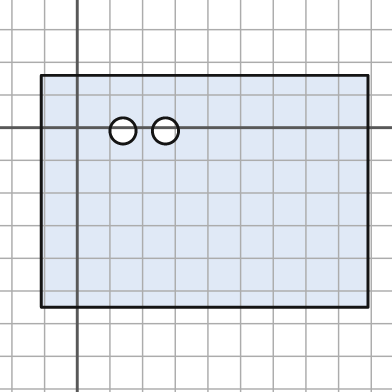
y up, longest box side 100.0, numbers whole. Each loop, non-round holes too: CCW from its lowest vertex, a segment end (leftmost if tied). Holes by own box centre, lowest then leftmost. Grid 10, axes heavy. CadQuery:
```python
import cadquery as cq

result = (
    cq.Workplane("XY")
    .moveTo(-11.0, -55.0)
    .lineTo(89.0, -55.0)
    .lineTo(89.0, 16.0)
    .lineTo(-11.0, 16.0)
    .close()
    .moveTo(14.0, -1.0)
    .circle(4.0)
    .moveTo(27.0, -1.0)
    .circle(4.0)
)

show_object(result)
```